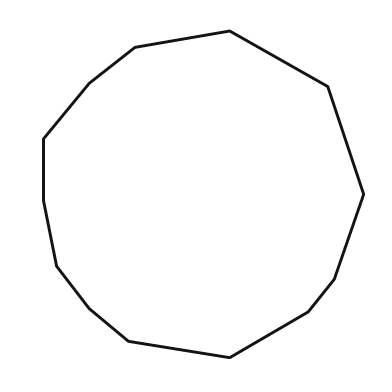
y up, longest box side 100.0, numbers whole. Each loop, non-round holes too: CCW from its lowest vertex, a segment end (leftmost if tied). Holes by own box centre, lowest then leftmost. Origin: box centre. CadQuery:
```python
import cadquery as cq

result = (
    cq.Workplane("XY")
    .moveTo(8.0, -50.0)
    .lineTo(32.0, -36.0)
    .lineTo(40.0, -26.0)
    .lineTo(49.0, 0.0)
    .lineTo(38.0, 33.0)
    .lineTo(8.0, 50.0)
    .lineTo(-21.0, 45.0)
    .lineTo(-35.0, 34.0)
    .lineTo(-49.0, 17.0)
    .lineTo(-49.0, -2.0)
    .lineTo(-45.0, -22.0)
    .lineTo(-35.0, -35.0)
    .lineTo(-23.0, -45.0)
    .close()
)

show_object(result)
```